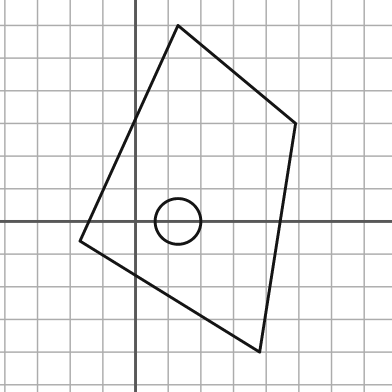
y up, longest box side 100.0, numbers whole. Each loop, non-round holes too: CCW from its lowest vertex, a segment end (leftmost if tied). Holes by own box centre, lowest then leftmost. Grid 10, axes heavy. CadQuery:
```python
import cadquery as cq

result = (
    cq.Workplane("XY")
    .moveTo(38.0, -40.0)
    .lineTo(49.0, 30.0)
    .lineTo(13.0, 60.0)
    .lineTo(-17.0, -6.0)
    .close()
    .moveTo(13.0, 0.0)
    .circle(7.0)
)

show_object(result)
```